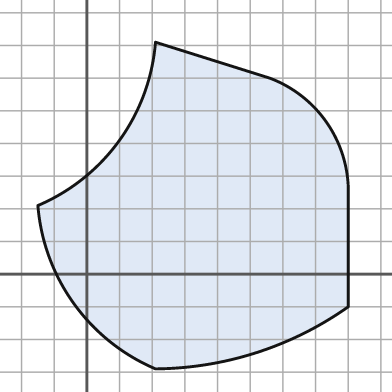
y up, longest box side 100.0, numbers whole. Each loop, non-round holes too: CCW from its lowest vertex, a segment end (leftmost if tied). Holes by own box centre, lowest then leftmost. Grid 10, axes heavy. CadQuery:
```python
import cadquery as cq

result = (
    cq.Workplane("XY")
    .moveTo(21.0, -29.0)
    .threePointArc((52.0, -24.0), (80.0, -10.0))
    .lineTo(80.0, 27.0)
    .threePointArc((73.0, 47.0), (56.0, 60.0))
    .lineTo(21.0, 71.0)
    .threePointArc((10.0, 41.0), (-15.0, 21.0))
    .threePointArc((-4.0, -9.0), (21.0, -29.0))
    .close()
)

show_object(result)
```